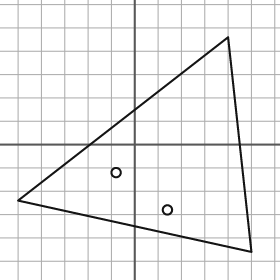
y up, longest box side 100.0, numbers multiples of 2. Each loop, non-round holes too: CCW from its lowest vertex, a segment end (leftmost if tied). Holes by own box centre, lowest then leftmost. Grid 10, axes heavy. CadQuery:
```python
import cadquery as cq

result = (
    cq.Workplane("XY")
    .moveTo(50.0, -46.0)
    .lineTo(40.0, 46.0)
    .lineTo(-50.0, -24.0)
    .close()
    .moveTo(14.0, -28.0)
    .circle(2.0)
    .moveTo(-8.0, -12.0)
    .circle(2.0)
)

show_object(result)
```